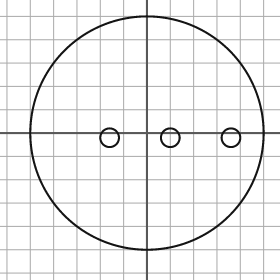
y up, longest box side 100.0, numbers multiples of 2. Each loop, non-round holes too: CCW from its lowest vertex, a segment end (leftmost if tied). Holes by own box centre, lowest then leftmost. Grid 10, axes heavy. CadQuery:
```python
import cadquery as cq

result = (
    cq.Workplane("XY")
    .moveTo(0.0, 0.0)
    .circle(50.0)
    .moveTo(-16.0, -2.0)
    .circle(4.0)
    .moveTo(10.0, -2.0)
    .circle(4.0)
    .moveTo(36.0, -2.0)
    .circle(4.0)
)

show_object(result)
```